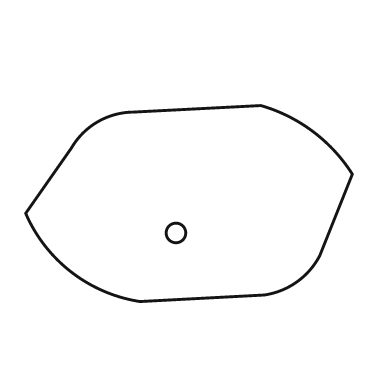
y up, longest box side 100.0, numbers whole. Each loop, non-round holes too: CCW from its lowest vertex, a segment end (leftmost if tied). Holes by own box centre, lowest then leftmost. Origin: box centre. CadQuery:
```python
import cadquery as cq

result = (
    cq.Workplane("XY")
    .moveTo(-15.0, -30.0)
    .lineTo(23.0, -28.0)
    .threePointArc((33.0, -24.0), (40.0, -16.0))
    .lineTo(50.0, 9.0)
    .threePointArc((38.0, 22.0), (22.0, 30.0))
    .lineTo(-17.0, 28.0)
    .threePointArc((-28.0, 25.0), (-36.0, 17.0))
    .lineTo(-50.0, -3.0)
    .threePointArc((-36.0, -21.0), (-15.0, -30.0))
    .close()
    .moveTo(-4.0, -9.0)
    .circle(3.0)
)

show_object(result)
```